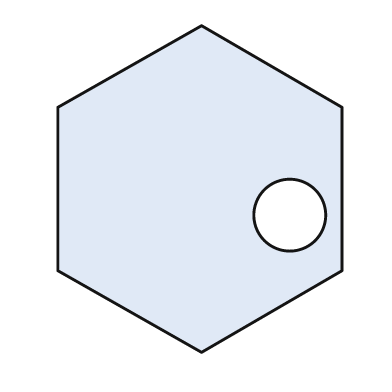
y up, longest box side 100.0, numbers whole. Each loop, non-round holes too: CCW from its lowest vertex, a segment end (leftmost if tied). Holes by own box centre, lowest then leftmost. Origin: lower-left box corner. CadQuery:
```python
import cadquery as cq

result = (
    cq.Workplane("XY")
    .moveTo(44.0, 0.0)
    .lineTo(87.0, 25.0)
    .lineTo(87.0, 75.0)
    .lineTo(44.0, 100.0)
    .lineTo(0.0, 75.0)
    .lineTo(0.0, 25.0)
    .close()
    .moveTo(71.0, 42.0)
    .circle(11.0)
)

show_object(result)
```